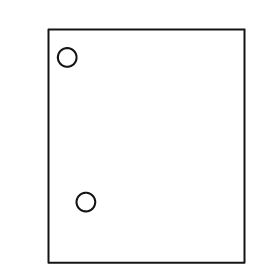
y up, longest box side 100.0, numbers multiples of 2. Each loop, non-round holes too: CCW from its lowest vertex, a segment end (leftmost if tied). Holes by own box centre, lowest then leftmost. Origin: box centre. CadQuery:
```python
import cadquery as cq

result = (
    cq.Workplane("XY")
    .moveTo(-42.0, -50.0)
    .lineTo(42.0, -50.0)
    .lineTo(42.0, 50.0)
    .lineTo(-42.0, 50.0)
    .close()
    .moveTo(-26.0, -24.0)
    .circle(4.0)
    .moveTo(-34.0, 38.0)
    .circle(4.0)
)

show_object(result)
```